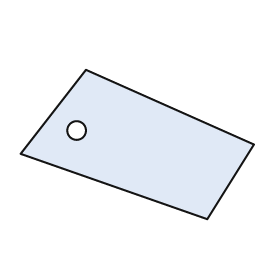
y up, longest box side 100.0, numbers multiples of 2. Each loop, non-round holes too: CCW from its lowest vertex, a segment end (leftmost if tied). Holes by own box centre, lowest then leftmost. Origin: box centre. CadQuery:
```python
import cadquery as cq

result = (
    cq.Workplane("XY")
    .moveTo(30.0, -32.0)
    .lineTo(50.0, 0.0)
    .lineTo(-22.0, 32.0)
    .lineTo(-50.0, -4.0)
    .close()
    .moveTo(-26.0, 6.0)
    .circle(4.0)
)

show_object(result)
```